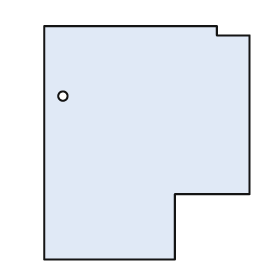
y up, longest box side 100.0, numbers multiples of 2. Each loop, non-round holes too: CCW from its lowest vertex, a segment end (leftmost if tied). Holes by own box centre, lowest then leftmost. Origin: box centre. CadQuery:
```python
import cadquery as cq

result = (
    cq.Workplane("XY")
    .moveTo(-44.0, -50.0)
    .lineTo(12.0, -50.0)
    .lineTo(12.0, -22.0)
    .lineTo(44.0, -22.0)
    .lineTo(44.0, 46.0)
    .lineTo(30.0, 46.0)
    .lineTo(30.0, 50.0)
    .lineTo(-44.0, 50.0)
    .close()
    .moveTo(-36.0, 20.0)
    .circle(2.0)
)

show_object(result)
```